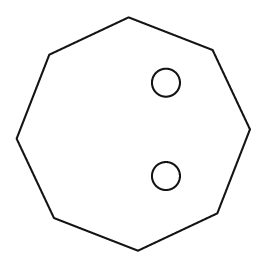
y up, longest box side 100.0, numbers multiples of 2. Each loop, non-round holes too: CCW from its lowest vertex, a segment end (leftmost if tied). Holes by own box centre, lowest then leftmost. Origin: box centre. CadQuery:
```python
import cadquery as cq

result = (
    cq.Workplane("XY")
    .moveTo(2.0, -50.0)
    .lineTo(36.0, -34.0)
    .lineTo(50.0, 2.0)
    .lineTo(34.0, 36.0)
    .lineTo(-2.0, 50.0)
    .lineTo(-36.0, 34.0)
    .lineTo(-50.0, -2.0)
    .lineTo(-34.0, -36.0)
    .close()
    .moveTo(14.0, -18.0)
    .circle(6.0)
    .moveTo(14.0, 22.0)
    .circle(6.0)
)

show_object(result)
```